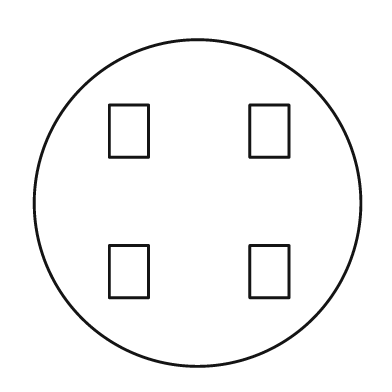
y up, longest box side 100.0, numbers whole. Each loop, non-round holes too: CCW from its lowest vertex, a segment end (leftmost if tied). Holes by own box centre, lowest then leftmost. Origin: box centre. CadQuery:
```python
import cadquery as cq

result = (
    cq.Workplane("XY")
    .moveTo(0.0, 0.0)
    .circle(50.0)
    .moveTo(-27.0, -29.0)
    .lineTo(-15.0, -29.0)
    .lineTo(-15.0, -13.0)
    .lineTo(-27.0, -13.0)
    .close()
    .moveTo(16.0, -29.0)
    .lineTo(28.0, -29.0)
    .lineTo(28.0, -13.0)
    .lineTo(16.0, -13.0)
    .close()
    .moveTo(-27.0, 14.0)
    .lineTo(-15.0, 14.0)
    .lineTo(-15.0, 30.0)
    .lineTo(-27.0, 30.0)
    .close()
    .moveTo(16.0, 14.0)
    .lineTo(28.0, 14.0)
    .lineTo(28.0, 30.0)
    .lineTo(16.0, 30.0)
    .close()
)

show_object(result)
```